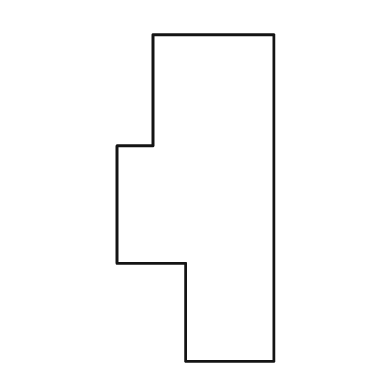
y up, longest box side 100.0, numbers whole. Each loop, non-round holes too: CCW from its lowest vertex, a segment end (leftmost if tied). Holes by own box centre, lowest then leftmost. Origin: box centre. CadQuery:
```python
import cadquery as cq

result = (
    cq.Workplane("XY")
    .moveTo(-3.0, -50.0)
    .lineTo(24.0, -50.0)
    .lineTo(24.0, 50.0)
    .lineTo(-13.0, 50.0)
    .lineTo(-13.0, 16.0)
    .lineTo(-24.0, 16.0)
    .lineTo(-24.0, -20.0)
    .lineTo(-3.0, -20.0)
    .close()
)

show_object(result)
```